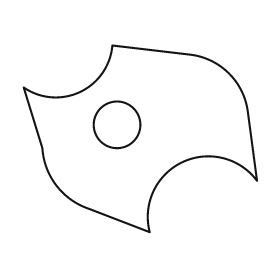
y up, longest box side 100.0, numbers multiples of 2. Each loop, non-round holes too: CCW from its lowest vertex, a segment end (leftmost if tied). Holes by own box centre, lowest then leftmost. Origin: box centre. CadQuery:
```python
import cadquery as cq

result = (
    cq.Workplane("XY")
    .moveTo(4.0, -40.0)
    .threePointArc((18.0, -10.0), (50.0, -18.0))
    .lineTo(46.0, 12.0)
    .threePointArc((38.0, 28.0), (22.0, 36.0))
    .lineTo(-12.0, 40.0)
    .threePointArc((-26.0, 20.0), (-50.0, 22.0))
    .lineTo(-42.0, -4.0)
    .threePointArc((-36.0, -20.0), (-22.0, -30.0))
    .close()
    .moveTo(-10.0, 6.0)
    .circle(10.0)
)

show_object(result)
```